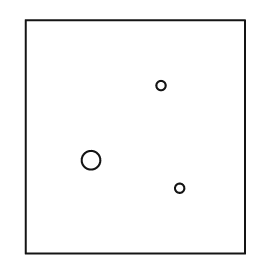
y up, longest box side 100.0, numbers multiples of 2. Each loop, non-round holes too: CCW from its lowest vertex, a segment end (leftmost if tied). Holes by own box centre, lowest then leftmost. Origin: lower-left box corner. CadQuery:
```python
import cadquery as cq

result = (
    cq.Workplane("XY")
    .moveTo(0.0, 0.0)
    .lineTo(94.0, 0.0)
    .lineTo(94.0, 100.0)
    .lineTo(0.0, 100.0)
    .close()
    .moveTo(66.0, 28.0)
    .circle(2.0)
    .moveTo(28.0, 40.0)
    .circle(4.0)
    .moveTo(58.0, 72.0)
    .circle(2.0)
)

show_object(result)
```